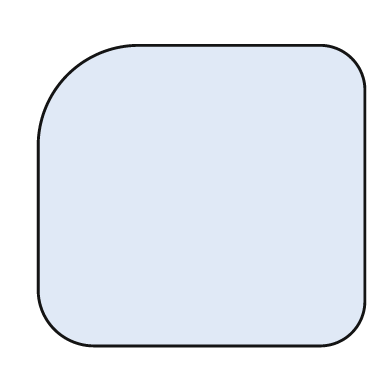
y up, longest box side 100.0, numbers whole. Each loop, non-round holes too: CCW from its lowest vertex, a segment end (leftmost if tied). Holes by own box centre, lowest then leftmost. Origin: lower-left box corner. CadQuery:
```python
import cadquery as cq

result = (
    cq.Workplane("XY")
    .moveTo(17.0, 0.0)
    .lineTo(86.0, 0.0)
    .threePointArc((96.0, 4.0), (100.0, 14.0))
    .lineTo(100.0, 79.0)
    .threePointArc((96.0, 88.0), (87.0, 92.0))
    .lineTo(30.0, 92.0)
    .threePointArc((9.0, 83.0), (0.0, 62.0))
    .lineTo(0.0, 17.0)
    .threePointArc((5.0, 5.0), (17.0, 0.0))
    .close()
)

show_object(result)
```